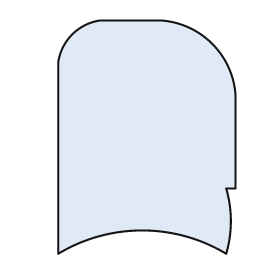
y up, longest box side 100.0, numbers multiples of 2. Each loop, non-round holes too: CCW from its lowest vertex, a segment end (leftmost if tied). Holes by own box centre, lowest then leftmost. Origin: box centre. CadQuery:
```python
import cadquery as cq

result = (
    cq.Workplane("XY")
    .moveTo(-38.0, -50.0)
    .threePointArc((-2.0, -40.0), (34.0, -50.0))
    .threePointArc((36.0, -36.0), (34.0, -22.0))
    .lineTo(38.0, -22.0)
    .lineTo(38.0, 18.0)
    .threePointArc((28.0, 40.0), (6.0, 50.0))
    .lineTo(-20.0, 50.0)
    .threePointArc((-32.0, 44.0), (-38.0, 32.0))
    .close()
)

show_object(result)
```